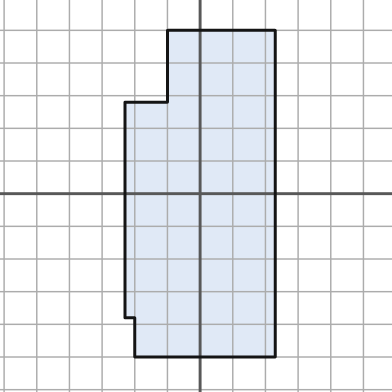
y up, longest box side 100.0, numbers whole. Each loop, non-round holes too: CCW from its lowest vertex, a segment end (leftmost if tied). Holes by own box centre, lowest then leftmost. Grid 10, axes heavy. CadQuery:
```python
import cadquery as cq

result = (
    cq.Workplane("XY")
    .moveTo(-20.0, -50.0)
    .lineTo(23.0, -50.0)
    .lineTo(23.0, 50.0)
    .lineTo(-10.0, 50.0)
    .lineTo(-10.0, 28.0)
    .lineTo(-23.0, 28.0)
    .lineTo(-23.0, -38.0)
    .lineTo(-20.0, -38.0)
    .close()
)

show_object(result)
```